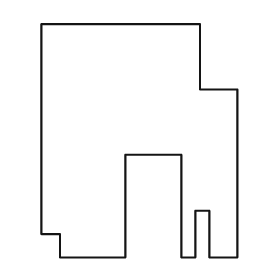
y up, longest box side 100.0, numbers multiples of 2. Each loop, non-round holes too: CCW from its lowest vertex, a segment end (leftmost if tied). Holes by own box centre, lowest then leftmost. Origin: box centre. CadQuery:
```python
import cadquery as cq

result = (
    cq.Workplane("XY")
    .moveTo(-34.0, -50.0)
    .lineTo(-6.0, -50.0)
    .lineTo(-6.0, -6.0)
    .lineTo(18.0, -6.0)
    .lineTo(18.0, -50.0)
    .lineTo(24.0, -50.0)
    .lineTo(24.0, -30.0)
    .lineTo(30.0, -30.0)
    .lineTo(30.0, -50.0)
    .lineTo(42.0, -50.0)
    .lineTo(42.0, 22.0)
    .lineTo(26.0, 22.0)
    .lineTo(26.0, 50.0)
    .lineTo(-42.0, 50.0)
    .lineTo(-42.0, -40.0)
    .lineTo(-34.0, -40.0)
    .close()
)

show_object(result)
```